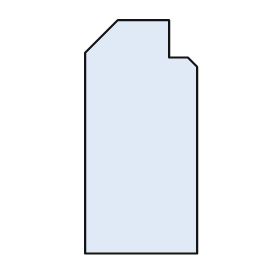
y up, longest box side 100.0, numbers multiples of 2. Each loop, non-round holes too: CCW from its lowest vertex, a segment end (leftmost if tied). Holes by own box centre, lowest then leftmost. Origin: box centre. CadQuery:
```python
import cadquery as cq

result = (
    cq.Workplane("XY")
    .moveTo(-24.0, -50.0)
    .lineTo(24.0, -50.0)
    .lineTo(24.0, 30.0)
    .lineTo(20.0, 34.0)
    .lineTo(12.0, 34.0)
    .lineTo(12.0, 50.0)
    .lineTo(-10.0, 50.0)
    .lineTo(-24.0, 36.0)
    .close()
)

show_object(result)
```